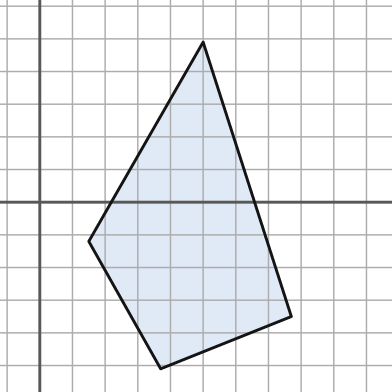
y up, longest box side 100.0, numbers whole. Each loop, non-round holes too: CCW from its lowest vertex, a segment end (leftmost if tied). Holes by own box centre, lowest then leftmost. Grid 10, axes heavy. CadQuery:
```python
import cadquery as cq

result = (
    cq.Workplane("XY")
    .moveTo(37.0, -51.0)
    .lineTo(77.0, -35.0)
    .lineTo(50.0, 49.0)
    .lineTo(15.0, -12.0)
    .close()
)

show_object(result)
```